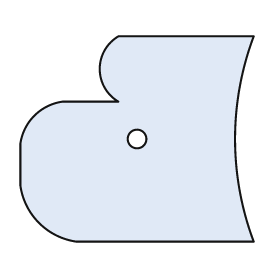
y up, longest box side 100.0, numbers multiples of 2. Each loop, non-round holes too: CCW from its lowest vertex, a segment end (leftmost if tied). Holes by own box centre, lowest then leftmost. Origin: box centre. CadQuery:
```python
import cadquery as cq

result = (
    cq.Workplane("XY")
    .moveTo(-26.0, -44.0)
    .lineTo(50.0, -44.0)
    .threePointArc((42.0, 0.0), (50.0, 44.0))
    .lineTo(-8.0, 44.0)
    .threePointArc((-16.0, 30.0), (-8.0, 16.0))
    .lineTo(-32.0, 16.0)
    .threePointArc((-44.0, 10.0), (-50.0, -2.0))
    .lineTo(-50.0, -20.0)
    .threePointArc((-42.0, -36.0), (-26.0, -44.0))
    .close()
    .moveTo(0.0, 0.0)
    .circle(4.0)
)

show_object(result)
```